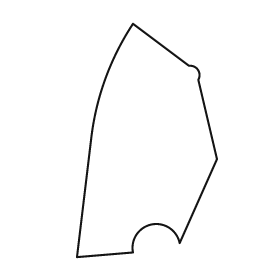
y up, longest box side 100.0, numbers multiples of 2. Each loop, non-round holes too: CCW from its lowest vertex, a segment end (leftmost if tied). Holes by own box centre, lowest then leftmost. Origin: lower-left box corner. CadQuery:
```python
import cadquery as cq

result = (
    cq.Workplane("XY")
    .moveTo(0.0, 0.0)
    .lineTo(24.0, 2.0)
    .threePointArc((32.0, 14.0), (44.0, 6.0))
    .lineTo(60.0, 42.0)
    .lineTo(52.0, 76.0)
    .threePointArc((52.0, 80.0), (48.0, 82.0))
    .lineTo(24.0, 100.0)
    .threePointArc((12.0, 76.0), (6.0, 50.0))
    .close()
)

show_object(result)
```